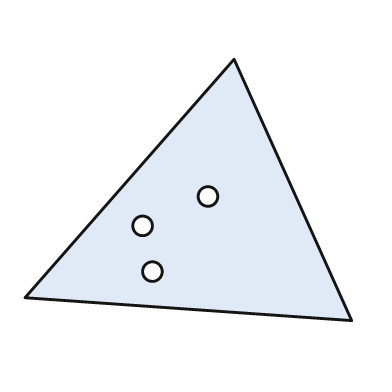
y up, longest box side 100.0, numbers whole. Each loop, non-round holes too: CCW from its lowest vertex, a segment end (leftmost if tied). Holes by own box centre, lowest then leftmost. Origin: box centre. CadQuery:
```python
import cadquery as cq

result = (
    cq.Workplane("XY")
    .moveTo(50.0, -40.0)
    .lineTo(14.0, 40.0)
    .lineTo(-50.0, -33.0)
    .close()
    .moveTo(-11.0, -25.0)
    .circle(3.0)
    .moveTo(-14.0, -11.0)
    .circle(3.0)
    .moveTo(6.0, -2.0)
    .circle(3.0)
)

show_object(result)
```